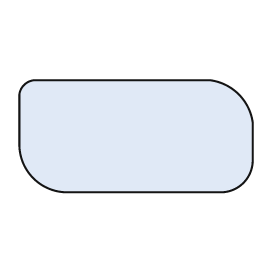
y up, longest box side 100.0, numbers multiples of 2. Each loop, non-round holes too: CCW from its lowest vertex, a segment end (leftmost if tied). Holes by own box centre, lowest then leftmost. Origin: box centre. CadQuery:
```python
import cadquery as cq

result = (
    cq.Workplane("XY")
    .moveTo(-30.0, -24.0)
    .lineTo(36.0, -24.0)
    .threePointArc((46.0, -20.0), (50.0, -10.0))
    .lineTo(50.0, 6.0)
    .threePointArc((44.0, 18.0), (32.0, 24.0))
    .lineTo(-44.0, 24.0)
    .threePointArc((-48.0, 22.0), (-50.0, 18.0))
    .lineTo(-50.0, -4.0)
    .threePointArc((-44.0, -18.0), (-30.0, -24.0))
    .close()
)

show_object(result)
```